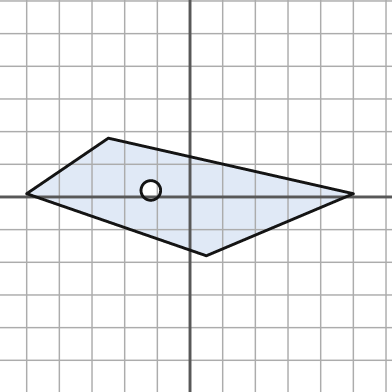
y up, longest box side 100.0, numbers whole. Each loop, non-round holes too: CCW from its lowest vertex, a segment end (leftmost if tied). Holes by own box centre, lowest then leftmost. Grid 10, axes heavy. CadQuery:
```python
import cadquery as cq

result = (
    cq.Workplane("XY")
    .moveTo(5.0, -18.0)
    .lineTo(50.0, 1.0)
    .lineTo(-25.0, 18.0)
    .lineTo(-50.0, 1.0)
    .close()
    .moveTo(-12.0, 2.0)
    .circle(3.0)
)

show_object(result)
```